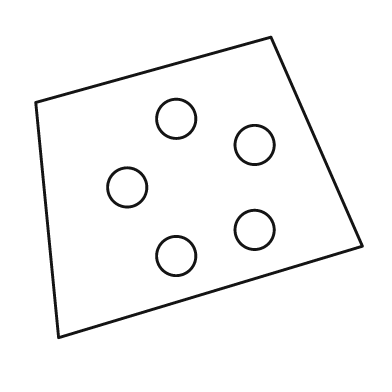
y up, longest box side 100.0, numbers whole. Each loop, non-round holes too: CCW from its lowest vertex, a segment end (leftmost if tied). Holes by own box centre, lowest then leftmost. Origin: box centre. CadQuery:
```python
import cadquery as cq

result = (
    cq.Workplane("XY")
    .moveTo(-43.0, -46.0)
    .lineTo(50.0, -18.0)
    .lineTo(22.0, 46.0)
    .lineTo(-50.0, 26.0)
    .close()
    .moveTo(-7.0, -21.0)
    .circle(6.0)
    .moveTo(17.0, -13.0)
    .circle(6.0)
    .moveTo(-22.0, 0.0)
    .circle(6.0)
    .moveTo(17.0, 13.0)
    .circle(6.0)
    .moveTo(-7.0, 21.0)
    .circle(6.0)
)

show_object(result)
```